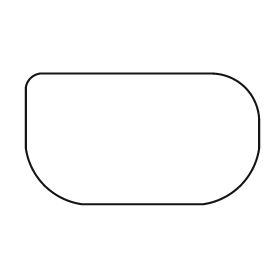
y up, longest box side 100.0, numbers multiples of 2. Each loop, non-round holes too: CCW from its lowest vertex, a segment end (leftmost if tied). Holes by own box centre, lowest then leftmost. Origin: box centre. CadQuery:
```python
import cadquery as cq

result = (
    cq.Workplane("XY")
    .moveTo(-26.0, -28.0)
    .lineTo(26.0, -28.0)
    .threePointArc((42.0, -20.0), (50.0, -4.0))
    .lineTo(50.0, 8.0)
    .threePointArc((44.0, 22.0), (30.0, 28.0))
    .lineTo(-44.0, 28.0)
    .threePointArc((-48.0, 26.0), (-50.0, 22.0))
    .lineTo(-50.0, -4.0)
    .threePointArc((-42.0, -20.0), (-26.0, -28.0))
    .close()
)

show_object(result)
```